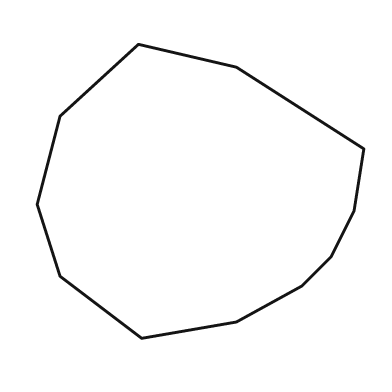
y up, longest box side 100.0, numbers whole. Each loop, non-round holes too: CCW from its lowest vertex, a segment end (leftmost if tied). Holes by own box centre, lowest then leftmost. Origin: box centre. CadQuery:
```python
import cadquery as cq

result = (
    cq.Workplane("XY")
    .moveTo(-18.0, -45.0)
    .lineTo(11.0, -40.0)
    .lineTo(31.0, -29.0)
    .lineTo(40.0, -20.0)
    .lineTo(47.0, -6.0)
    .lineTo(50.0, 13.0)
    .lineTo(11.0, 38.0)
    .lineTo(-19.0, 45.0)
    .lineTo(-43.0, 23.0)
    .lineTo(-50.0, -4.0)
    .lineTo(-43.0, -26.0)
    .close()
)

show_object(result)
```